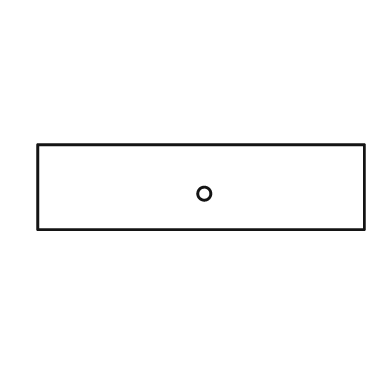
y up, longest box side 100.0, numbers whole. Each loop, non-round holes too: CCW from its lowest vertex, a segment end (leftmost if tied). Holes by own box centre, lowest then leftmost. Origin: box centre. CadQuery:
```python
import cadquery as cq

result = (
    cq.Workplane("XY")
    .moveTo(-50.0, -13.0)
    .lineTo(50.0, -13.0)
    .lineTo(50.0, 13.0)
    .lineTo(-50.0, 13.0)
    .close()
    .moveTo(1.0, -2.0)
    .circle(2.0)
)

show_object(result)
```